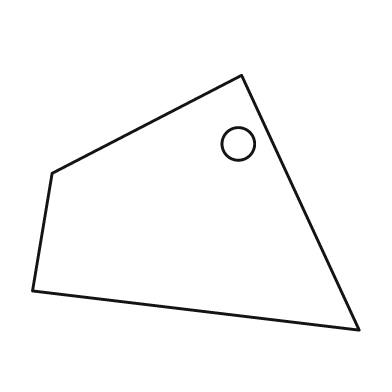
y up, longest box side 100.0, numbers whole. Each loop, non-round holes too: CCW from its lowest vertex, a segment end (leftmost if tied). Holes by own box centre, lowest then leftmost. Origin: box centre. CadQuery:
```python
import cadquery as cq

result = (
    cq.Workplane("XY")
    .moveTo(50.0, -39.0)
    .lineTo(14.0, 39.0)
    .lineTo(-44.0, 9.0)
    .lineTo(-50.0, -27.0)
    .close()
    .moveTo(13.0, 18.0)
    .circle(5.0)
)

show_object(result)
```